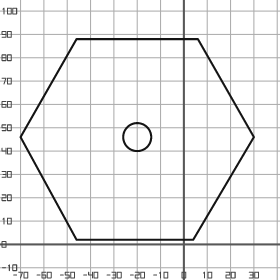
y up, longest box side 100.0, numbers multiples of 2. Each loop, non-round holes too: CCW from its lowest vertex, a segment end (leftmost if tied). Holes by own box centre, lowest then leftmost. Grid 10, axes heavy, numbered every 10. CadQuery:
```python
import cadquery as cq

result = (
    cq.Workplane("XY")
    .moveTo(-46.0, 2.0)
    .lineTo(4.0, 2.0)
    .lineTo(30.0, 46.0)
    .lineTo(6.0, 88.0)
    .lineTo(-46.0, 88.0)
    .lineTo(-70.0, 46.0)
    .close()
    .moveTo(-20.0, 46.0)
    .circle(6.0)
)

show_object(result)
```